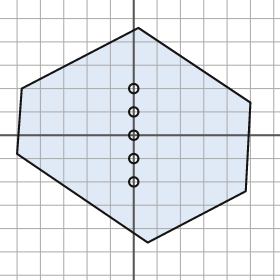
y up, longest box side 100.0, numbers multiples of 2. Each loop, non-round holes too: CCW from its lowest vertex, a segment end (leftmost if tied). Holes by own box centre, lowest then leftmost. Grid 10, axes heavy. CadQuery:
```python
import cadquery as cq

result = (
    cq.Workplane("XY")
    .moveTo(6.0, -46.0)
    .lineTo(48.0, -24.0)
    .lineTo(50.0, 14.0)
    .lineTo(2.0, 46.0)
    .lineTo(-48.0, 20.0)
    .lineTo(-50.0, -8.0)
    .close()
    .moveTo(0.0, -20.0)
    .circle(2.0)
    .moveTo(0.0, -10.0)
    .circle(2.0)
    .moveTo(0.0, 0.0)
    .circle(2.0)
    .moveTo(0.0, 10.0)
    .circle(2.0)
    .moveTo(0.0, 20.0)
    .circle(2.0)
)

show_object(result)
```